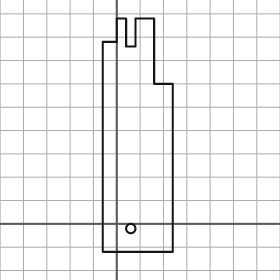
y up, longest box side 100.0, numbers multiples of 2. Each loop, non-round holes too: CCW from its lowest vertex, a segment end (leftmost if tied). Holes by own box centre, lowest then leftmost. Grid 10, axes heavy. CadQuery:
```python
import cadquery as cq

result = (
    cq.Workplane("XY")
    .moveTo(-6.0, -12.0)
    .lineTo(24.0, -12.0)
    .lineTo(24.0, 60.0)
    .lineTo(16.0, 60.0)
    .lineTo(16.0, 88.0)
    .lineTo(8.0, 88.0)
    .lineTo(8.0, 76.0)
    .lineTo(4.0, 76.0)
    .lineTo(4.0, 88.0)
    .lineTo(0.0, 88.0)
    .lineTo(0.0, 78.0)
    .lineTo(-6.0, 78.0)
    .close()
    .moveTo(6.0, -2.0)
    .circle(2.0)
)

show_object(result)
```